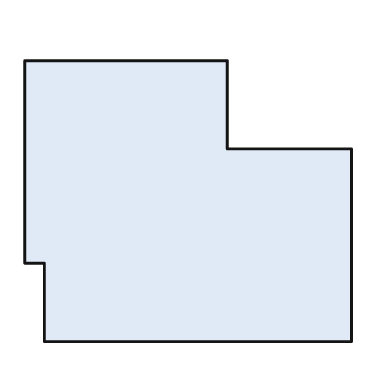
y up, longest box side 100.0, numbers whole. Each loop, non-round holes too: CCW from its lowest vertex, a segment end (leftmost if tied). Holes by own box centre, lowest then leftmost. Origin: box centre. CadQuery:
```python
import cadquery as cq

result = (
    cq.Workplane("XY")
    .moveTo(-44.0, -43.0)
    .lineTo(50.0, -43.0)
    .lineTo(50.0, 16.0)
    .lineTo(12.0, 16.0)
    .lineTo(12.0, 43.0)
    .lineTo(-50.0, 43.0)
    .lineTo(-50.0, -19.0)
    .lineTo(-44.0, -19.0)
    .close()
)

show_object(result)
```